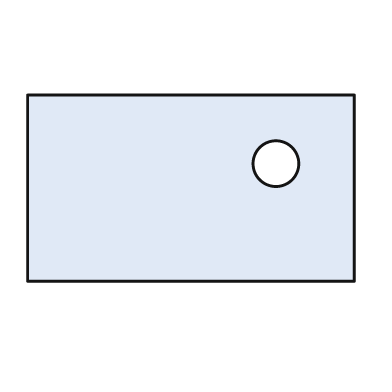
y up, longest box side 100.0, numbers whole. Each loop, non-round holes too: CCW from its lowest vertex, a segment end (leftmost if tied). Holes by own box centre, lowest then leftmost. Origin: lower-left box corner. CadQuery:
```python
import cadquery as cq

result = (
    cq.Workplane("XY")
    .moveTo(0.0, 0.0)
    .lineTo(100.0, 0.0)
    .lineTo(100.0, 57.0)
    .lineTo(0.0, 57.0)
    .close()
    .moveTo(76.0, 36.0)
    .circle(7.0)
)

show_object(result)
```